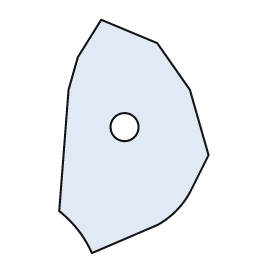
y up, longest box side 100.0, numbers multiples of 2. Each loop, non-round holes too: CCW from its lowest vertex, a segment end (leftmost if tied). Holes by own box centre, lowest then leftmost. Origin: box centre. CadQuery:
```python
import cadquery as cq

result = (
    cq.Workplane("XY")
    .moveTo(-18.0, -50.0)
    .lineTo(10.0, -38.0)
    .threePointArc((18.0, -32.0), (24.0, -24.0))
    .lineTo(32.0, -8.0)
    .lineTo(24.0, 20.0)
    .lineTo(10.0, 40.0)
    .lineTo(-14.0, 50.0)
    .lineTo(-24.0, 34.0)
    .lineTo(-28.0, 20.0)
    .lineTo(-32.0, -32.0)
    .threePointArc((-24.0, -40.0), (-18.0, -50.0))
    .close()
    .moveTo(-4.0, 4.0)
    .circle(6.0)
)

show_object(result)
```